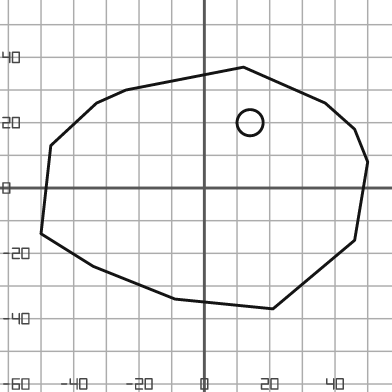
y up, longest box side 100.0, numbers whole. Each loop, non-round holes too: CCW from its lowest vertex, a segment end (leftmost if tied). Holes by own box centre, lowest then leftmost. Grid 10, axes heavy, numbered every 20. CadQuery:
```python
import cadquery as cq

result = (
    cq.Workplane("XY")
    .moveTo(21.0, -37.0)
    .lineTo(46.0, -16.0)
    .lineTo(50.0, 8.0)
    .lineTo(46.0, 18.0)
    .lineTo(37.0, 26.0)
    .lineTo(12.0, 37.0)
    .lineTo(-24.0, 30.0)
    .lineTo(-33.0, 26.0)
    .lineTo(-47.0, 13.0)
    .lineTo(-50.0, -14.0)
    .lineTo(-34.0, -24.0)
    .lineTo(-9.0, -34.0)
    .close()
    .moveTo(14.0, 20.0)
    .circle(4.0)
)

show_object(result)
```